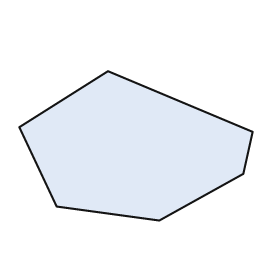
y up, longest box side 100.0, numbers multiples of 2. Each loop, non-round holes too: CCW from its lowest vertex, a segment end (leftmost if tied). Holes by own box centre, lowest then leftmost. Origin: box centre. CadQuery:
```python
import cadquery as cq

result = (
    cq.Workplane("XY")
    .moveTo(10.0, -32.0)
    .lineTo(46.0, -12.0)
    .lineTo(50.0, 6.0)
    .lineTo(-12.0, 32.0)
    .lineTo(-50.0, 8.0)
    .lineTo(-34.0, -26.0)
    .close()
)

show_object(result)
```